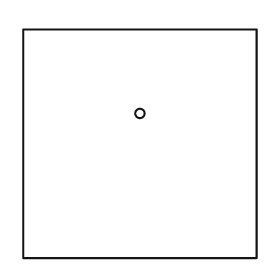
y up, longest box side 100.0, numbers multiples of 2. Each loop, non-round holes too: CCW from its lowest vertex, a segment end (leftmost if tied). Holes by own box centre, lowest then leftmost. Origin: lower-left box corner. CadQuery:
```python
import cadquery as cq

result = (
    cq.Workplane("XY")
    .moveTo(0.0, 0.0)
    .lineTo(100.0, 0.0)
    .lineTo(100.0, 98.0)
    .lineTo(0.0, 98.0)
    .close()
    .moveTo(50.0, 62.0)
    .circle(2.0)
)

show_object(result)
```